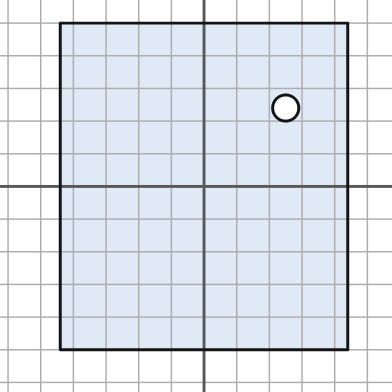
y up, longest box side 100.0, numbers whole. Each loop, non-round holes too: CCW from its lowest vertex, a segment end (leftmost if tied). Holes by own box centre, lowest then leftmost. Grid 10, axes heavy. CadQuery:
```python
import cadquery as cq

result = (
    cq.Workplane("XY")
    .moveTo(-44.0, -50.0)
    .lineTo(44.0, -50.0)
    .lineTo(44.0, 50.0)
    .lineTo(-44.0, 50.0)
    .close()
    .moveTo(25.0, 24.0)
    .circle(4.0)
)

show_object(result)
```